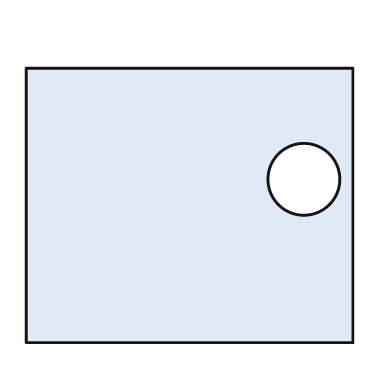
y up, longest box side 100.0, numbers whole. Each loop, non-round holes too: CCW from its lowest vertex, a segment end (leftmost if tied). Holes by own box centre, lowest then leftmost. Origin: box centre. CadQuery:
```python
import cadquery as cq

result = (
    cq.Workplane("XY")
    .moveTo(-50.0, -42.0)
    .lineTo(50.0, -42.0)
    .lineTo(50.0, 42.0)
    .lineTo(-50.0, 42.0)
    .close()
    .moveTo(35.0, 8.0)
    .circle(11.0)
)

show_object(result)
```